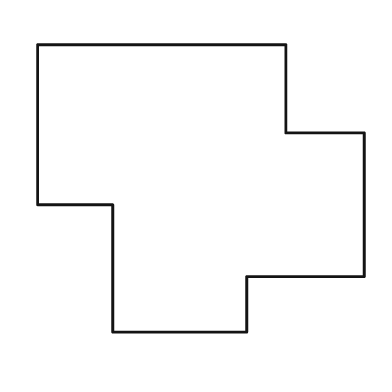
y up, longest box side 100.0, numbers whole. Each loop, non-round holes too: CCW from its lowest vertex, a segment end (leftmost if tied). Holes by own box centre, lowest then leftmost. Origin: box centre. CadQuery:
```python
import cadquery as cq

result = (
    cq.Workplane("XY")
    .moveTo(-27.0, -44.0)
    .lineTo(14.0, -44.0)
    .lineTo(14.0, -27.0)
    .lineTo(50.0, -27.0)
    .lineTo(50.0, 17.0)
    .lineTo(26.0, 17.0)
    .lineTo(26.0, 44.0)
    .lineTo(-50.0, 44.0)
    .lineTo(-50.0, -5.0)
    .lineTo(-27.0, -5.0)
    .close()
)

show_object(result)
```